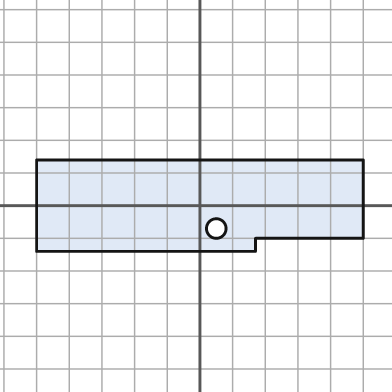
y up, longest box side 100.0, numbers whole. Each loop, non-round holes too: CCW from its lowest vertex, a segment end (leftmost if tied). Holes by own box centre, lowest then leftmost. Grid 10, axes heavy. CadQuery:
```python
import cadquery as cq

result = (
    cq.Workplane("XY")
    .moveTo(-50.0, -14.0)
    .lineTo(17.0, -14.0)
    .lineTo(17.0, -10.0)
    .lineTo(50.0, -10.0)
    .lineTo(50.0, 14.0)
    .lineTo(-50.0, 14.0)
    .close()
    .moveTo(5.0, -7.0)
    .circle(3.0)
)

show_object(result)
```